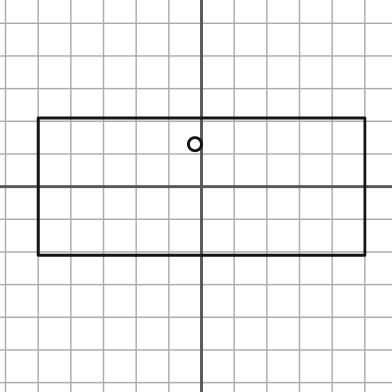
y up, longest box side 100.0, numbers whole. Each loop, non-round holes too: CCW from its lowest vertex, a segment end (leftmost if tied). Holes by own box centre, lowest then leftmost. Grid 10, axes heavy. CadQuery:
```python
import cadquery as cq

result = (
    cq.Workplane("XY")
    .moveTo(-50.0, -21.0)
    .lineTo(50.0, -21.0)
    .lineTo(50.0, 21.0)
    .lineTo(-50.0, 21.0)
    .close()
    .moveTo(-2.0, 13.0)
    .circle(2.0)
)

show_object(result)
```